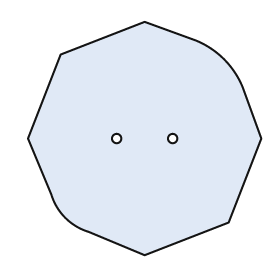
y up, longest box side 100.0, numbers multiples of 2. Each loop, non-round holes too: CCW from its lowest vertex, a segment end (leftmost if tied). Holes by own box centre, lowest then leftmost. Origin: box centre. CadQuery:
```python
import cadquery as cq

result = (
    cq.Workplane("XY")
    .moveTo(0.0, -50.0)
    .lineTo(36.0, -36.0)
    .lineTo(50.0, 0.0)
    .lineTo(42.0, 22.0)
    .threePointArc((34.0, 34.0), (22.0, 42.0))
    .lineTo(0.0, 50.0)
    .lineTo(-36.0, 36.0)
    .lineTo(-50.0, 0.0)
    .lineTo(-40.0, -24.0)
    .threePointArc((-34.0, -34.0), (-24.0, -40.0))
    .close()
    .moveTo(-12.0, 0.0)
    .circle(2.0)
    .moveTo(12.0, 0.0)
    .circle(2.0)
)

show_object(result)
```